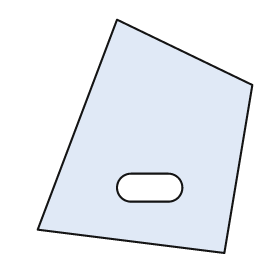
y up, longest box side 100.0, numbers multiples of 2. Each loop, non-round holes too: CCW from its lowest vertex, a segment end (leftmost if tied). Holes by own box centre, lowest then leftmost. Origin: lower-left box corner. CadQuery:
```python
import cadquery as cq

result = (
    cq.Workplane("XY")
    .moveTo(80.0, 0.0)
    .lineTo(92.0, 72.0)
    .lineTo(34.0, 100.0)
    .lineTo(0.0, 10.0)
    .close()
    .moveTo(40.0, 22.0)
    .lineTo(56.0, 22.0)
    .threePointArc((62.0, 28.0), (56.0, 34.0))
    .lineTo(40.0, 34.0)
    .threePointArc((34.0, 28.0), (40.0, 22.0))
    .close()
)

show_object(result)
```